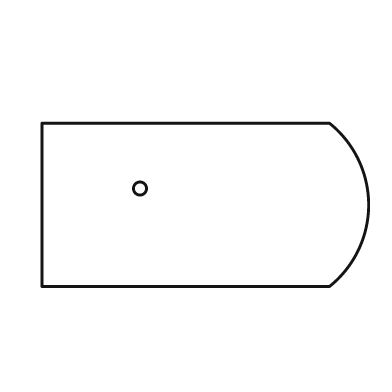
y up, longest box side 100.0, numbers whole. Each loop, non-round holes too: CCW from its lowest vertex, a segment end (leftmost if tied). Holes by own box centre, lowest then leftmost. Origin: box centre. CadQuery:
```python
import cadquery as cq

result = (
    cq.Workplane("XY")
    .moveTo(-50.0, -25.0)
    .lineTo(38.0, -25.0)
    .threePointArc((50.0, 0.0), (38.0, 25.0))
    .lineTo(-50.0, 25.0)
    .close()
    .moveTo(-20.0, 5.0)
    .circle(2.0)
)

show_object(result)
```